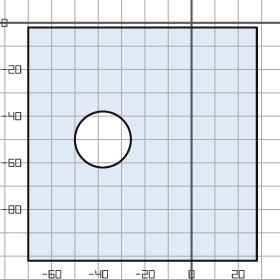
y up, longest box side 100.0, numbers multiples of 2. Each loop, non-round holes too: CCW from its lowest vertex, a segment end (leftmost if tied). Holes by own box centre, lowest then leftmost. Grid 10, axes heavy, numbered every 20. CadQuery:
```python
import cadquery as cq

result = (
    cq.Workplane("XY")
    .moveTo(-70.0, -102.0)
    .lineTo(28.0, -102.0)
    .lineTo(28.0, -2.0)
    .lineTo(-70.0, -2.0)
    .close()
    .moveTo(-38.0, -50.0)
    .circle(12.0)
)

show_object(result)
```